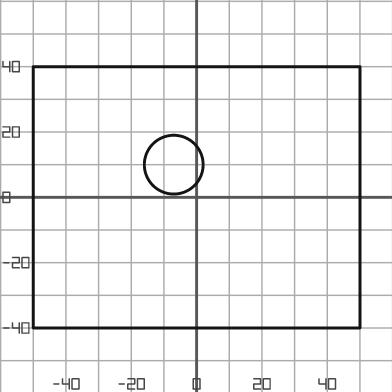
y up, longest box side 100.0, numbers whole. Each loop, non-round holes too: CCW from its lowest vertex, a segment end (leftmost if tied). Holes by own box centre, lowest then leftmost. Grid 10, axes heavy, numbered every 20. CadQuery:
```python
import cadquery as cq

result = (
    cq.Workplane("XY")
    .moveTo(-50.0, -40.0)
    .lineTo(50.0, -40.0)
    .lineTo(50.0, 40.0)
    .lineTo(-50.0, 40.0)
    .close()
    .moveTo(-7.0, 10.0)
    .circle(9.0)
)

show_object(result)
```